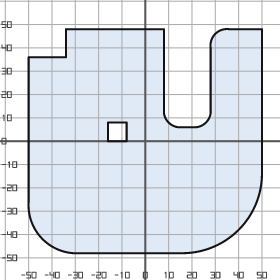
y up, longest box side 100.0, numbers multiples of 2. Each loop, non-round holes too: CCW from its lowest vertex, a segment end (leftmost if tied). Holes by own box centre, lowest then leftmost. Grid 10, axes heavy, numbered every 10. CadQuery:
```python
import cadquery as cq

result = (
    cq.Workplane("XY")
    .moveTo(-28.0, -48.0)
    .lineTo(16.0, -48.0)
    .threePointArc((40.0, -38.0), (50.0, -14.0))
    .lineTo(50.0, 48.0)
    .lineTo(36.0, 48.0)
    .threePointArc((30.0, 46.0), (28.0, 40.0))
    .lineTo(28.0, 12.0)
    .threePointArc((26.0, 8.0), (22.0, 6.0))
    .lineTo(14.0, 6.0)
    .threePointArc((10.0, 8.0), (8.0, 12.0))
    .lineTo(8.0, 48.0)
    .lineTo(-34.0, 48.0)
    .lineTo(-34.0, 36.0)
    .lineTo(-50.0, 36.0)
    .lineTo(-50.0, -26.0)
    .threePointArc((-44.0, -42.0), (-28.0, -48.0))
    .close()
    .moveTo(-16.0, 0.0)
    .lineTo(-8.0, 0.0)
    .lineTo(-8.0, 8.0)
    .lineTo(-16.0, 8.0)
    .close()
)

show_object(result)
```